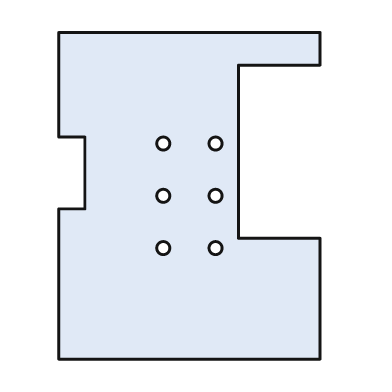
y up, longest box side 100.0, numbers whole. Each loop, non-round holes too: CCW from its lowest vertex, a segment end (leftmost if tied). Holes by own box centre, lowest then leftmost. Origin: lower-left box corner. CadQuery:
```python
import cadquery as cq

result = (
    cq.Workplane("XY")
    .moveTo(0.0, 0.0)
    .lineTo(80.0, 0.0)
    .lineTo(80.0, 37.0)
    .lineTo(55.0, 37.0)
    .lineTo(55.0, 90.0)
    .lineTo(80.0, 90.0)
    .lineTo(80.0, 100.0)
    .lineTo(0.0, 100.0)
    .lineTo(0.0, 68.0)
    .lineTo(8.0, 68.0)
    .lineTo(8.0, 46.0)
    .lineTo(0.0, 46.0)
    .close()
    .moveTo(32.0, 34.0)
    .circle(2.0)
    .moveTo(48.0, 34.0)
    .circle(2.0)
    .moveTo(32.0, 50.0)
    .circle(2.0)
    .moveTo(48.0, 50.0)
    .circle(2.0)
    .moveTo(32.0, 66.0)
    .circle(2.0)
    .moveTo(48.0, 66.0)
    .circle(2.0)
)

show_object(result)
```